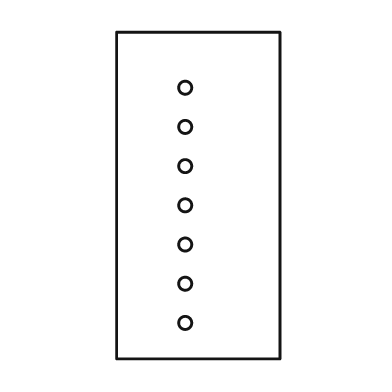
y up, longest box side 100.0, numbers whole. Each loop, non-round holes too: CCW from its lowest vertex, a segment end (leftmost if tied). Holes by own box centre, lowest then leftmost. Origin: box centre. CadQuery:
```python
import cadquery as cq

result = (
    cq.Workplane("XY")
    .moveTo(-25.0, -50.0)
    .lineTo(25.0, -50.0)
    .lineTo(25.0, 50.0)
    .lineTo(-25.0, 50.0)
    .close()
    .moveTo(-4.0, -39.0)
    .circle(2.0)
    .moveTo(-4.0, -27.0)
    .circle(2.0)
    .moveTo(-4.0, -15.0)
    .circle(2.0)
    .moveTo(-4.0, -3.0)
    .circle(2.0)
    .moveTo(-4.0, 9.0)
    .circle(2.0)
    .moveTo(-4.0, 21.0)
    .circle(2.0)
    .moveTo(-4.0, 33.0)
    .circle(2.0)
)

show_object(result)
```